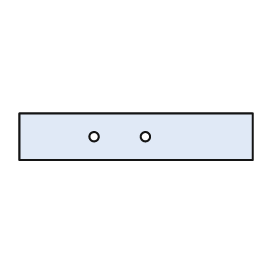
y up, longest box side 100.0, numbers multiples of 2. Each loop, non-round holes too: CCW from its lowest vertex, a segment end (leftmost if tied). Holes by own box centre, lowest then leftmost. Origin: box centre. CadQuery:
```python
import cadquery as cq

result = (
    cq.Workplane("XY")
    .moveTo(-50.0, -10.0)
    .lineTo(50.0, -10.0)
    .lineTo(50.0, 10.0)
    .lineTo(-50.0, 10.0)
    .close()
    .moveTo(-18.0, 0.0)
    .circle(2.0)
    .moveTo(4.0, 0.0)
    .circle(2.0)
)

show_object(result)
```